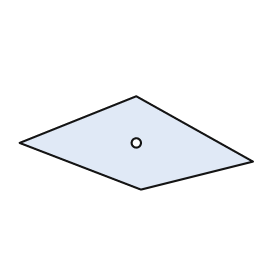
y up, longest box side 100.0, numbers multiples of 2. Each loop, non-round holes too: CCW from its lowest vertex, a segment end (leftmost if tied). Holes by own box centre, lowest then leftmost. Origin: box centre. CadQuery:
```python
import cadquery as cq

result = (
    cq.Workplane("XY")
    .moveTo(2.0, -20.0)
    .lineTo(50.0, -8.0)
    .lineTo(0.0, 20.0)
    .lineTo(-50.0, 0.0)
    .close()
    .moveTo(0.0, 0.0)
    .circle(2.0)
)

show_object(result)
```